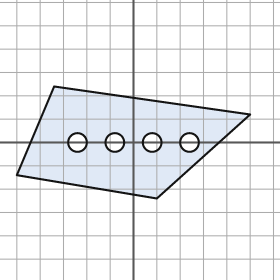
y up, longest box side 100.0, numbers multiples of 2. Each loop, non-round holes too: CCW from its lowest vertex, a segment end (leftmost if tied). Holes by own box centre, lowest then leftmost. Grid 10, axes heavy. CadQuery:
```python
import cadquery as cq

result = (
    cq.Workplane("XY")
    .moveTo(10.0, -24.0)
    .lineTo(50.0, 12.0)
    .lineTo(-34.0, 24.0)
    .lineTo(-50.0, -14.0)
    .close()
    .moveTo(-24.0, 0.0)
    .circle(4.0)
    .moveTo(-8.0, 0.0)
    .circle(4.0)
    .moveTo(8.0, 0.0)
    .circle(4.0)
    .moveTo(24.0, 0.0)
    .circle(4.0)
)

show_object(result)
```